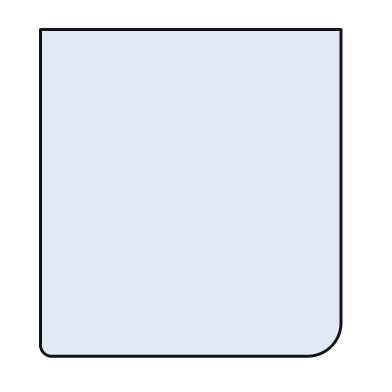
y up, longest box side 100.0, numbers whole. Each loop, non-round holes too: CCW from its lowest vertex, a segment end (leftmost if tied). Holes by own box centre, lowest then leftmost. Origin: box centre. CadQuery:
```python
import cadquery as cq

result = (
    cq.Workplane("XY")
    .moveTo(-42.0, -50.0)
    .lineTo(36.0, -50.0)
    .threePointArc((43.0, -47.0), (46.0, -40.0))
    .lineTo(46.0, 50.0)
    .lineTo(-46.0, 50.0)
    .lineTo(-46.0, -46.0)
    .threePointArc((-45.0, -49.0), (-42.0, -50.0))
    .close()
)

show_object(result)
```